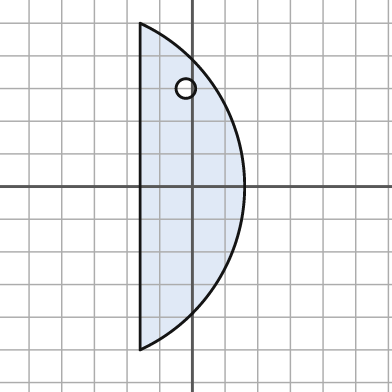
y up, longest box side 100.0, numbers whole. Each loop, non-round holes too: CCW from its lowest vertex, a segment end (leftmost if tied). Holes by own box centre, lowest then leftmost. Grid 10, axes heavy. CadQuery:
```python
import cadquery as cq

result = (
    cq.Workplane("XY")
    .moveTo(-16.0, -50.0)
    .threePointArc((16.0, 0.0), (-16.0, 50.0))
    .close()
    .moveTo(-2.0, 30.0)
    .circle(3.0)
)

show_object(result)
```